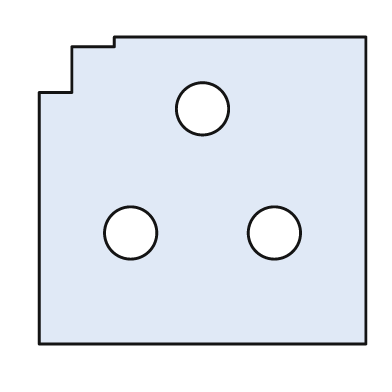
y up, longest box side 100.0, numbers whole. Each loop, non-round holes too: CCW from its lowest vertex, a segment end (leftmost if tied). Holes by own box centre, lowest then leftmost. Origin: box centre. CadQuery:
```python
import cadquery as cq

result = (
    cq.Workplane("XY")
    .moveTo(-50.0, -47.0)
    .lineTo(50.0, -47.0)
    .lineTo(50.0, 47.0)
    .lineTo(-27.0, 47.0)
    .lineTo(-27.0, 44.0)
    .lineTo(-40.0, 44.0)
    .lineTo(-40.0, 30.0)
    .lineTo(-50.0, 30.0)
    .close()
    .moveTo(-22.0, -13.0)
    .circle(8.0)
    .moveTo(22.0, -13.0)
    .circle(8.0)
    .moveTo(0.0, 25.0)
    .circle(8.0)
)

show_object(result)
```